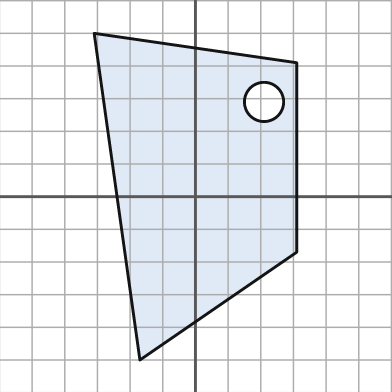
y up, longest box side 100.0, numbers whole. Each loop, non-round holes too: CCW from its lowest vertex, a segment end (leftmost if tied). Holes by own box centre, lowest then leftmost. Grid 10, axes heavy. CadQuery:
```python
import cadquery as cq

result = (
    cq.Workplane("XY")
    .moveTo(-17.0, -50.0)
    .lineTo(31.0, -17.0)
    .lineTo(31.0, 41.0)
    .lineTo(-31.0, 50.0)
    .close()
    .moveTo(21.0, 29.0)
    .circle(6.0)
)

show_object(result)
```